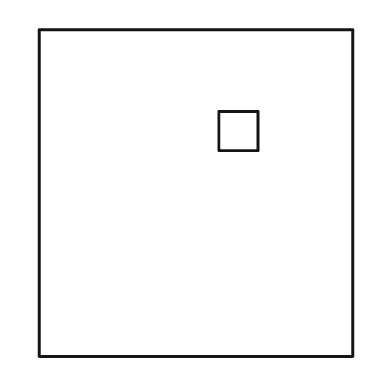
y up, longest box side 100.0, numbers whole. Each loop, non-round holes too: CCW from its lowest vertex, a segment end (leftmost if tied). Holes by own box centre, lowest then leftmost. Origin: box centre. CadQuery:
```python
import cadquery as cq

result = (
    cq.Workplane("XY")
    .moveTo(-48.0, -50.0)
    .lineTo(48.0, -50.0)
    .lineTo(48.0, 50.0)
    .lineTo(-48.0, 50.0)
    .close()
    .moveTo(7.0, 13.0)
    .lineTo(19.0, 13.0)
    .lineTo(19.0, 25.0)
    .lineTo(7.0, 25.0)
    .close()
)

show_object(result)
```